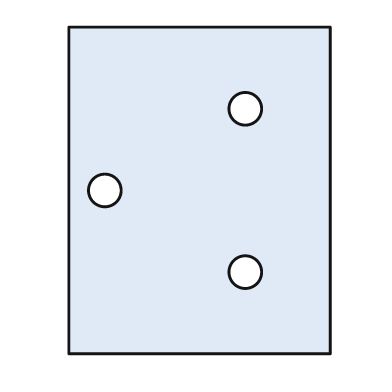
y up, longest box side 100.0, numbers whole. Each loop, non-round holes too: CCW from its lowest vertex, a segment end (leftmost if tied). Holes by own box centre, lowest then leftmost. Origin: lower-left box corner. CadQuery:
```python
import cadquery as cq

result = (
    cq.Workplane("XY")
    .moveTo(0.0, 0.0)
    .lineTo(80.0, 0.0)
    .lineTo(80.0, 100.0)
    .lineTo(0.0, 100.0)
    .close()
    .moveTo(54.0, 25.0)
    .circle(5.0)
    .moveTo(11.0, 50.0)
    .circle(5.0)
    .moveTo(54.0, 75.0)
    .circle(5.0)
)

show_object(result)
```